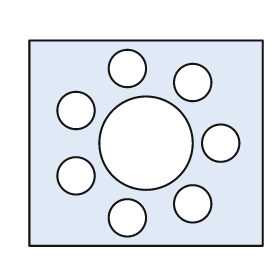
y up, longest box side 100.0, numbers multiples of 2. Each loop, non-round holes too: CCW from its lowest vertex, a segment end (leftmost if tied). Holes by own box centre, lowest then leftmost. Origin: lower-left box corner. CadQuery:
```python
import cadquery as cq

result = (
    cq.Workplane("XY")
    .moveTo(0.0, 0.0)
    .lineTo(100.0, 0.0)
    .lineTo(100.0, 88.0)
    .lineTo(0.0, 88.0)
    .close()
    .moveTo(42.0, 12.0)
    .circle(8.0)
    .moveTo(70.0, 18.0)
    .circle(8.0)
    .moveTo(20.0, 30.0)
    .circle(8.0)
    .moveTo(50.0, 44.0)
    .circle(20.0)
    .moveTo(82.0, 44.0)
    .circle(8.0)
    .moveTo(20.0, 58.0)
    .circle(8.0)
    .moveTo(70.0, 70.0)
    .circle(8.0)
    .moveTo(42.0, 76.0)
    .circle(8.0)
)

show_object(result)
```